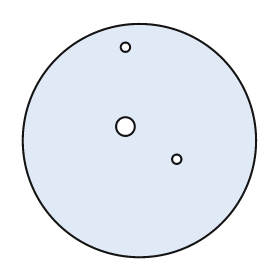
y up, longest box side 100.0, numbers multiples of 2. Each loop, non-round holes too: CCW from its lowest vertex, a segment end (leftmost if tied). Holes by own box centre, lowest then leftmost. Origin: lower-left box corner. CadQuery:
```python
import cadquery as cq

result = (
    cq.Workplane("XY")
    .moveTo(50.0, 50.0)
    .circle(50.0)
    .moveTo(66.0, 42.0)
    .circle(2.0)
    .moveTo(44.0, 56.0)
    .circle(4.0)
    .moveTo(44.0, 90.0)
    .circle(2.0)
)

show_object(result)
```